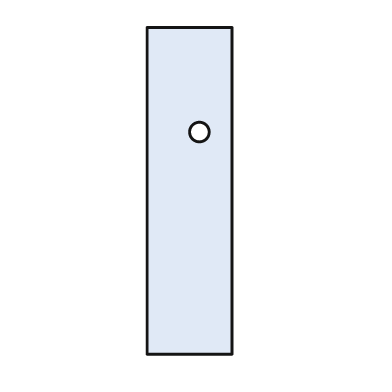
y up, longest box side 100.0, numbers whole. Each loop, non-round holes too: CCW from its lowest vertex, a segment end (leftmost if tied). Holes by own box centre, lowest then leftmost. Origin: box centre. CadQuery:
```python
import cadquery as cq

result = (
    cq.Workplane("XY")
    .moveTo(-13.0, -50.0)
    .lineTo(13.0, -50.0)
    .lineTo(13.0, 50.0)
    .lineTo(-13.0, 50.0)
    .close()
    .moveTo(3.0, 18.0)
    .circle(3.0)
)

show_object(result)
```